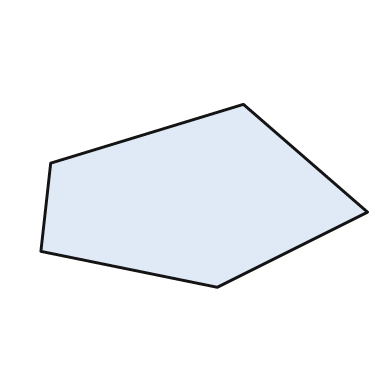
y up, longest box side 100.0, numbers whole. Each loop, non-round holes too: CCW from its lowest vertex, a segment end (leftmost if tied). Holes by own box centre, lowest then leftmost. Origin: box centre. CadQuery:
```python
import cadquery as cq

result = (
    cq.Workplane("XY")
    .moveTo(4.0, -28.0)
    .lineTo(50.0, -5.0)
    .lineTo(12.0, 28.0)
    .lineTo(-47.0, 10.0)
    .lineTo(-50.0, -17.0)
    .close()
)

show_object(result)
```